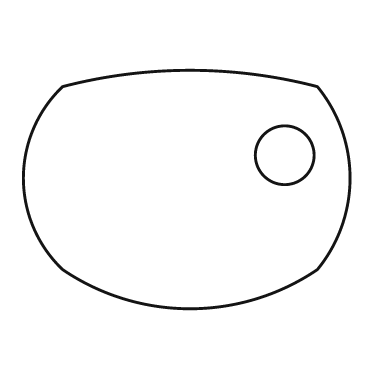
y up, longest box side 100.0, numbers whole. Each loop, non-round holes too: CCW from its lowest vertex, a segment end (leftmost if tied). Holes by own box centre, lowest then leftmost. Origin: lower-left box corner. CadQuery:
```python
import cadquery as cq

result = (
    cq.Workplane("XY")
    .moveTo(12.0, 12.0)
    .threePointArc((51.0, 0.0), (90.0, 12.0))
    .threePointArc((100.0, 40.0), (90.0, 68.0))
    .threePointArc((51.0, 73.0), (12.0, 68.0))
    .threePointArc((0.0, 40.0), (12.0, 12.0))
    .close()
    .moveTo(80.0, 47.0)
    .circle(9.0)
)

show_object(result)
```